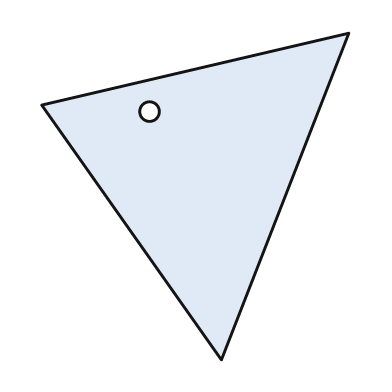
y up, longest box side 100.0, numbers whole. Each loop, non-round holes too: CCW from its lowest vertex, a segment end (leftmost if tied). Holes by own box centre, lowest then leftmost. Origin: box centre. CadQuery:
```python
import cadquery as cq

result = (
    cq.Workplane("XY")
    .moveTo(8.0, -50.0)
    .lineTo(47.0, 50.0)
    .lineTo(-47.0, 28.0)
    .close()
    .moveTo(-14.0, 26.0)
    .circle(3.0)
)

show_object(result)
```